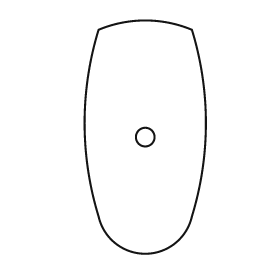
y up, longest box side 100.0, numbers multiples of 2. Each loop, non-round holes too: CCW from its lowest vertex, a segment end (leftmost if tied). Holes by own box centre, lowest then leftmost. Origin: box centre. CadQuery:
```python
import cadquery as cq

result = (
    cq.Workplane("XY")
    .moveTo(-20.0, -34.0)
    .threePointArc((0.0, -50.0), (20.0, -34.0))
    .threePointArc((26.0, 6.0), (20.0, 46.0))
    .threePointArc((0.0, 50.0), (-20.0, 46.0))
    .threePointArc((-26.0, 6.0), (-20.0, -34.0))
    .close()
    .moveTo(0.0, 0.0)
    .circle(4.0)
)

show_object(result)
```